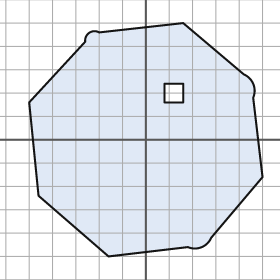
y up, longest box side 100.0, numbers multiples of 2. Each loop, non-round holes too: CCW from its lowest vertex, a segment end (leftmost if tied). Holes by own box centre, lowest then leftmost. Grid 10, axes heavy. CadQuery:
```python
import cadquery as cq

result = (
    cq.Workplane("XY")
    .moveTo(-16.0, -50.0)
    .lineTo(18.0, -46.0)
    .threePointArc((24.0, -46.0), (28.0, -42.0))
    .lineTo(50.0, -16.0)
    .lineTo(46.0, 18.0)
    .threePointArc((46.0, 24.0), (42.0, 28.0))
    .lineTo(16.0, 50.0)
    .lineTo(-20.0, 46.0)
    .threePointArc((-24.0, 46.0), (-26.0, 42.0))
    .lineTo(-50.0, 16.0)
    .lineTo(-46.0, -24.0)
    .close()
    .moveTo(8.0, 16.0)
    .lineTo(16.0, 16.0)
    .lineTo(16.0, 24.0)
    .lineTo(8.0, 24.0)
    .close()
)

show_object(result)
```